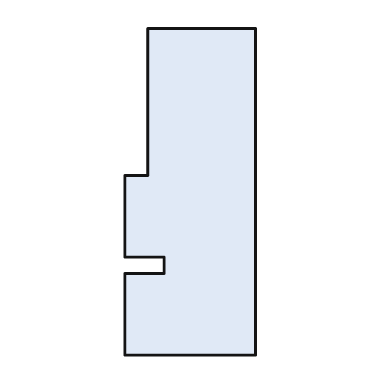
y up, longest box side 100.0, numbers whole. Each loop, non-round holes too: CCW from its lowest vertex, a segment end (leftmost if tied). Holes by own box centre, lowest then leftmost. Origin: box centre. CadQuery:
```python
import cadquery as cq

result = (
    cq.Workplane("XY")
    .moveTo(-20.0, -50.0)
    .lineTo(20.0, -50.0)
    .lineTo(20.0, 50.0)
    .lineTo(-13.0, 50.0)
    .lineTo(-13.0, 5.0)
    .lineTo(-20.0, 5.0)
    .lineTo(-20.0, -20.0)
    .lineTo(-8.0, -20.0)
    .lineTo(-8.0, -25.0)
    .lineTo(-20.0, -25.0)
    .close()
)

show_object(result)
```